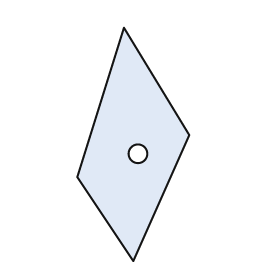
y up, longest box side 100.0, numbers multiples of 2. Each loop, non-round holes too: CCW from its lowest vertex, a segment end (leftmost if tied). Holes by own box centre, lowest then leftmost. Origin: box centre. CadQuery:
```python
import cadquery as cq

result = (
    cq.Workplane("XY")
    .moveTo(0.0, -50.0)
    .lineTo(24.0, 4.0)
    .lineTo(-4.0, 50.0)
    .lineTo(-24.0, -14.0)
    .close()
    .moveTo(2.0, -4.0)
    .circle(4.0)
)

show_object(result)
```